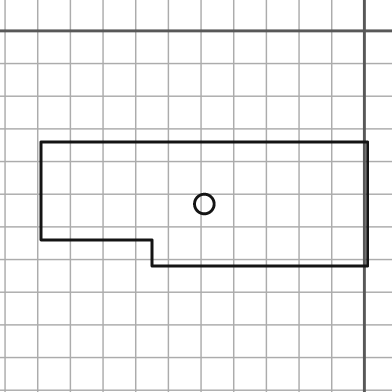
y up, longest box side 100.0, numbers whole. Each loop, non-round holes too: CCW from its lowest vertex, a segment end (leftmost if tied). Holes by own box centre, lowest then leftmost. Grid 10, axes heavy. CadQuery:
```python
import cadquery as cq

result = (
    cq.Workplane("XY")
    .moveTo(-65.0, -72.0)
    .lineTo(1.0, -72.0)
    .lineTo(1.0, -34.0)
    .lineTo(-99.0, -34.0)
    .lineTo(-99.0, -64.0)
    .lineTo(-65.0, -64.0)
    .close()
    .moveTo(-49.0, -53.0)
    .circle(3.0)
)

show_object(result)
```